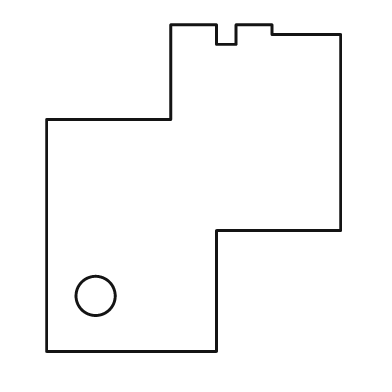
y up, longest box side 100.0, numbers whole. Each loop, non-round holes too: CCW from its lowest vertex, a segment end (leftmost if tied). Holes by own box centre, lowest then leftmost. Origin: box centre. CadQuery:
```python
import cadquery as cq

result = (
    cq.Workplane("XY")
    .moveTo(-45.0, -50.0)
    .lineTo(7.0, -50.0)
    .lineTo(7.0, -13.0)
    .lineTo(45.0, -13.0)
    .lineTo(45.0, 47.0)
    .lineTo(24.0, 47.0)
    .lineTo(24.0, 50.0)
    .lineTo(13.0, 50.0)
    .lineTo(13.0, 44.0)
    .lineTo(7.0, 44.0)
    .lineTo(7.0, 50.0)
    .lineTo(-7.0, 50.0)
    .lineTo(-7.0, 21.0)
    .lineTo(-45.0, 21.0)
    .close()
    .moveTo(-30.0, -33.0)
    .circle(6.0)
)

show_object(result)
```